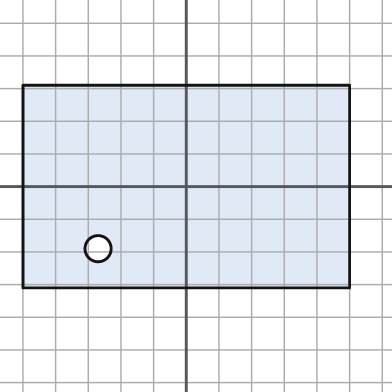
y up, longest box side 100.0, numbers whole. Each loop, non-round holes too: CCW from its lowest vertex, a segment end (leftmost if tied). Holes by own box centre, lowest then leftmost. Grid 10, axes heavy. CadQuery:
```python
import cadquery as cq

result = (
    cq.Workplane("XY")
    .moveTo(-50.0, -31.0)
    .lineTo(50.0, -31.0)
    .lineTo(50.0, 31.0)
    .lineTo(-50.0, 31.0)
    .close()
    .moveTo(-27.0, -19.0)
    .circle(4.0)
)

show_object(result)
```